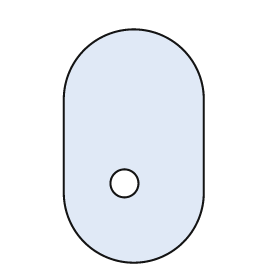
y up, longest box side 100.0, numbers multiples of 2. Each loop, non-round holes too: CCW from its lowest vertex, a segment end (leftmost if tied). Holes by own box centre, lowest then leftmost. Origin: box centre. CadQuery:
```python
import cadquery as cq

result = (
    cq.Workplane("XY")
    .moveTo(-30.0, -20.0)
    .threePointArc((0.0, -50.0), (30.0, -20.0))
    .lineTo(30.0, 20.0)
    .threePointArc((0.0, 50.0), (-30.0, 20.0))
    .close()
    .moveTo(-4.0, -16.0)
    .circle(6.0)
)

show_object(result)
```